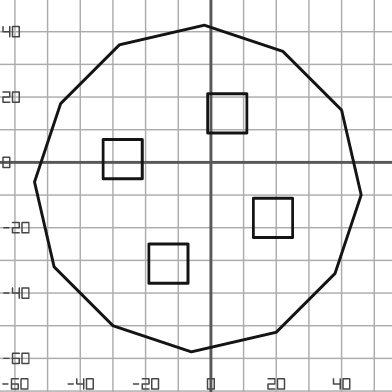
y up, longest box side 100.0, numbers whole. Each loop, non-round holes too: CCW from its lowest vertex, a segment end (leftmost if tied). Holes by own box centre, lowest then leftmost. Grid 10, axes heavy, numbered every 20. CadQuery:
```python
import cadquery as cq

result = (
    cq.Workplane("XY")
    .moveTo(-6.0, -58.0)
    .lineTo(20.0, -52.0)
    .lineTo(38.0, -34.0)
    .lineTo(46.0, -10.0)
    .lineTo(40.0, 16.0)
    .lineTo(22.0, 34.0)
    .lineTo(-2.0, 42.0)
    .lineTo(-28.0, 36.0)
    .lineTo(-46.0, 18.0)
    .lineTo(-54.0, -6.0)
    .lineTo(-48.0, -32.0)
    .lineTo(-30.0, -50.0)
    .close()
    .moveTo(-19.0, -37.0)
    .lineTo(-7.0, -37.0)
    .lineTo(-7.0, -25.0)
    .lineTo(-19.0, -25.0)
    .close()
    .moveTo(13.0, -23.0)
    .lineTo(25.0, -23.0)
    .lineTo(25.0, -11.0)
    .lineTo(13.0, -11.0)
    .close()
    .moveTo(-33.0, -5.0)
    .lineTo(-21.0, -5.0)
    .lineTo(-21.0, 7.0)
    .lineTo(-33.0, 7.0)
    .close()
    .moveTo(-1.0, 9.0)
    .lineTo(11.0, 9.0)
    .lineTo(11.0, 21.0)
    .lineTo(-1.0, 21.0)
    .close()
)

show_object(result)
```